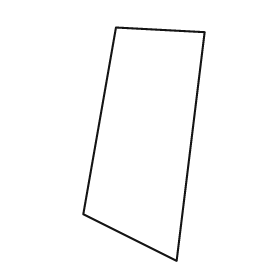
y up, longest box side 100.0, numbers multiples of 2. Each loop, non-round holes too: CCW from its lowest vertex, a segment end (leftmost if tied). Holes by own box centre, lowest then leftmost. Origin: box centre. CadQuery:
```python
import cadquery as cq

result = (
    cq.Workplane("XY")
    .moveTo(14.0, -50.0)
    .lineTo(26.0, 48.0)
    .lineTo(-12.0, 50.0)
    .lineTo(-26.0, -30.0)
    .close()
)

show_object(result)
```